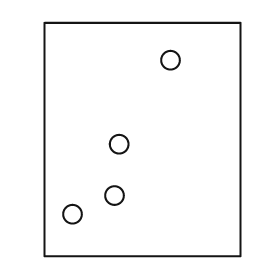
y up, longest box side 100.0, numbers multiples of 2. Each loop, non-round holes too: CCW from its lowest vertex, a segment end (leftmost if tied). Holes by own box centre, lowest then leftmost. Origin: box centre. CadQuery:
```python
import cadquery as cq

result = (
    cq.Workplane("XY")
    .moveTo(-42.0, -50.0)
    .lineTo(42.0, -50.0)
    .lineTo(42.0, 50.0)
    .lineTo(-42.0, 50.0)
    .close()
    .moveTo(-30.0, -32.0)
    .circle(4.0)
    .moveTo(-12.0, -24.0)
    .circle(4.0)
    .moveTo(-10.0, -2.0)
    .circle(4.0)
    .moveTo(12.0, 34.0)
    .circle(4.0)
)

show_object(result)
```